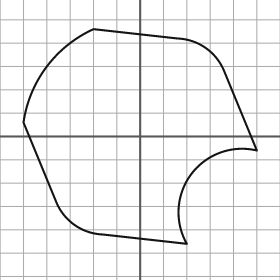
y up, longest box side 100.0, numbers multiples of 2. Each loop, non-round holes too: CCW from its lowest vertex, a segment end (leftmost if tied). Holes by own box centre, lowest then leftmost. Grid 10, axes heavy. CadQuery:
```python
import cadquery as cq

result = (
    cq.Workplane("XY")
    .moveTo(20.0, -46.0)
    .threePointArc((22.0, -16.0), (50.0, -6.0))
    .lineTo(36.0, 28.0)
    .threePointArc((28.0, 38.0), (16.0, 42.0))
    .lineTo(-20.0, 46.0)
    .threePointArc((-40.0, 30.0), (-50.0, 6.0))
    .lineTo(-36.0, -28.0)
    .threePointArc((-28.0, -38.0), (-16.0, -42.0))
    .close()
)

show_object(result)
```